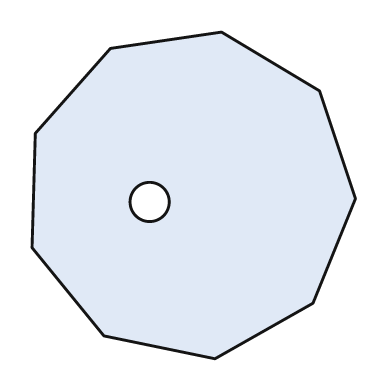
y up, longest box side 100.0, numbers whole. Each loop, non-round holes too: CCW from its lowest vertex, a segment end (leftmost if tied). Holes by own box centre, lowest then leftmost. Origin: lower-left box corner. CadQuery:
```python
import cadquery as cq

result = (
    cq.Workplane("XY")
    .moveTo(56.0, 0.0)
    .lineTo(86.0, 17.0)
    .lineTo(99.0, 49.0)
    .lineTo(88.0, 82.0)
    .lineTo(58.0, 100.0)
    .lineTo(24.0, 95.0)
    .lineTo(1.0, 69.0)
    .lineTo(0.0, 34.0)
    .lineTo(22.0, 7.0)
    .close()
    .moveTo(36.0, 48.0)
    .circle(6.0)
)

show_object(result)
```